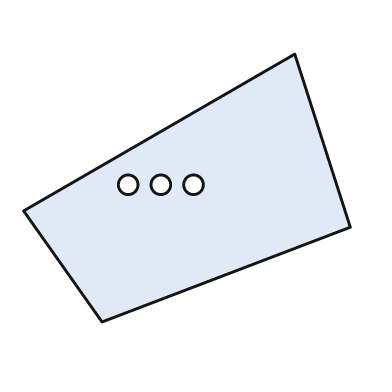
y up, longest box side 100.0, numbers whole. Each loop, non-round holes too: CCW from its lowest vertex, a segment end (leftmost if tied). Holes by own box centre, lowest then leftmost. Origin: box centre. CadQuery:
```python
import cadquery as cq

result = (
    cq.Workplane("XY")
    .moveTo(-26.0, -41.0)
    .lineTo(50.0, -12.0)
    .lineTo(33.0, 41.0)
    .lineTo(-50.0, -7.0)
    .close()
    .moveTo(-18.0, 1.0)
    .circle(3.0)
    .moveTo(-8.0, 1.0)
    .circle(3.0)
    .moveTo(2.0, 1.0)
    .circle(3.0)
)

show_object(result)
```